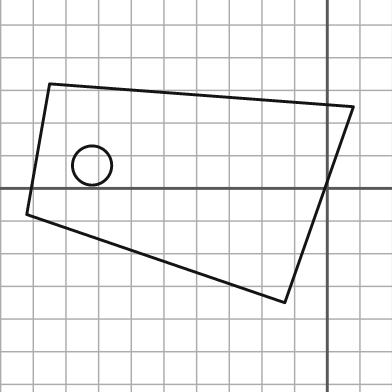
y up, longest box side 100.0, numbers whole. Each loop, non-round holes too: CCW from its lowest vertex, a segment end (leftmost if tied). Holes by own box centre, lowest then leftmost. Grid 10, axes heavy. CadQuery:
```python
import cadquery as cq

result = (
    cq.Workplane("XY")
    .moveTo(-13.0, -35.0)
    .lineTo(8.0, 25.0)
    .lineTo(-85.0, 32.0)
    .lineTo(-92.0, -8.0)
    .close()
    .moveTo(-72.0, 7.0)
    .circle(6.0)
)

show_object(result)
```